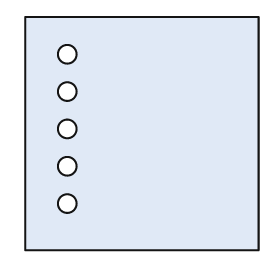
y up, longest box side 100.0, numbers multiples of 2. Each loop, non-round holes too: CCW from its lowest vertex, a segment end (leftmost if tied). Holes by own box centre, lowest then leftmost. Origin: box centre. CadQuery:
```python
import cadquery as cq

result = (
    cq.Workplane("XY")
    .moveTo(-50.0, -50.0)
    .lineTo(50.0, -50.0)
    .lineTo(50.0, 50.0)
    .lineTo(-50.0, 50.0)
    .close()
    .moveTo(-32.0, -30.0)
    .circle(4.0)
    .moveTo(-32.0, -14.0)
    .circle(4.0)
    .moveTo(-32.0, 2.0)
    .circle(4.0)
    .moveTo(-32.0, 18.0)
    .circle(4.0)
    .moveTo(-32.0, 34.0)
    .circle(4.0)
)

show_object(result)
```